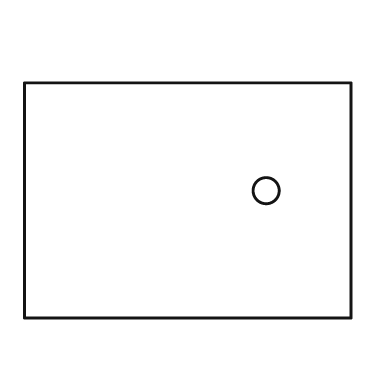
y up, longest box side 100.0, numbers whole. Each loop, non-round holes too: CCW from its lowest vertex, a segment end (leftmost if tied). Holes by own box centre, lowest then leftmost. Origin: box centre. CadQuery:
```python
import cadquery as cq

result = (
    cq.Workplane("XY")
    .moveTo(-50.0, -36.0)
    .lineTo(50.0, -36.0)
    .lineTo(50.0, 36.0)
    .lineTo(-50.0, 36.0)
    .close()
    .moveTo(24.0, 3.0)
    .circle(4.0)
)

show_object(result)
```